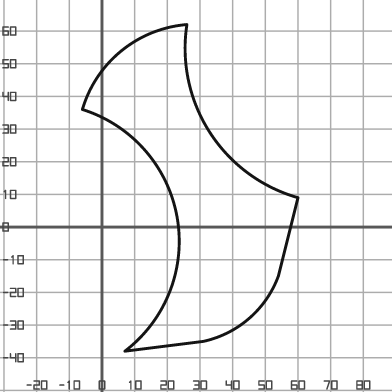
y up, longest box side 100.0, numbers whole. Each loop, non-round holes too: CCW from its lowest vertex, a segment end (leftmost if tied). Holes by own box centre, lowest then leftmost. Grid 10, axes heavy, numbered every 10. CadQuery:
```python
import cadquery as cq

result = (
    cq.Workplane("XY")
    .moveTo(7.0, -38.0)
    .lineTo(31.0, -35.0)
    .threePointArc((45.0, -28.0), (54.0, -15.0))
    .lineTo(60.0, 9.0)
    .threePointArc((33.0, 29.0), (26.0, 62.0))
    .threePointArc((6.0, 54.0), (-6.0, 36.0))
    .threePointArc((23.0, 3.0), (7.0, -38.0))
    .close()
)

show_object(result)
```